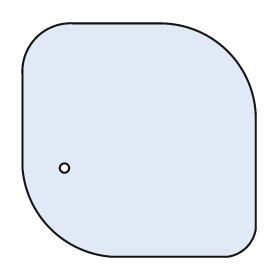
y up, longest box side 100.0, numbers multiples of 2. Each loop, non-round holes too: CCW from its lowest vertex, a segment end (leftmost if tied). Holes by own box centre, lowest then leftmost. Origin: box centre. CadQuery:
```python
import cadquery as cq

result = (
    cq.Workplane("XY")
    .moveTo(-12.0, -50.0)
    .lineTo(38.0, -50.0)
    .threePointArc((46.0, -46.0), (50.0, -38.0))
    .lineTo(50.0, 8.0)
    .threePointArc((38.0, 38.0), (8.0, 50.0))
    .lineTo(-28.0, 50.0)
    .threePointArc((-44.0, 44.0), (-50.0, 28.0))
    .lineTo(-50.0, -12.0)
    .threePointArc((-38.0, -38.0), (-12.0, -50.0))
    .close()
    .moveTo(-32.0, -12.0)
    .circle(2.0)
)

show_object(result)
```